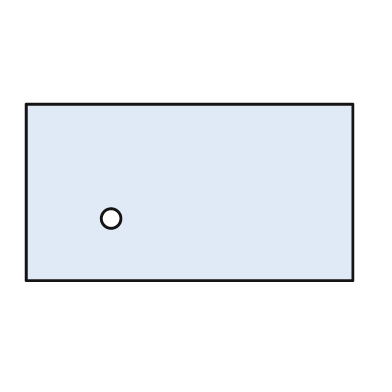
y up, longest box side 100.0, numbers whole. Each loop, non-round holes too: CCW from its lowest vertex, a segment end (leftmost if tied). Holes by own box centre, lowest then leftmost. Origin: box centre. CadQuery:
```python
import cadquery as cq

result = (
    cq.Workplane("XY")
    .moveTo(-50.0, -27.0)
    .lineTo(50.0, -27.0)
    .lineTo(50.0, 27.0)
    .lineTo(-50.0, 27.0)
    .close()
    .moveTo(-24.0, -8.0)
    .circle(3.0)
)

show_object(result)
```